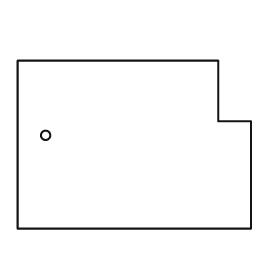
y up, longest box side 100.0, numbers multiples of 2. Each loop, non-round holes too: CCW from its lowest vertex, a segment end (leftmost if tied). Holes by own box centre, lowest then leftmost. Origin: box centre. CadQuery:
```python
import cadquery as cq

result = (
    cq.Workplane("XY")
    .moveTo(-50.0, -36.0)
    .lineTo(50.0, -36.0)
    .lineTo(50.0, 10.0)
    .lineTo(36.0, 10.0)
    .lineTo(36.0, 36.0)
    .lineTo(-50.0, 36.0)
    .close()
    .moveTo(-38.0, 4.0)
    .circle(2.0)
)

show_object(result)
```